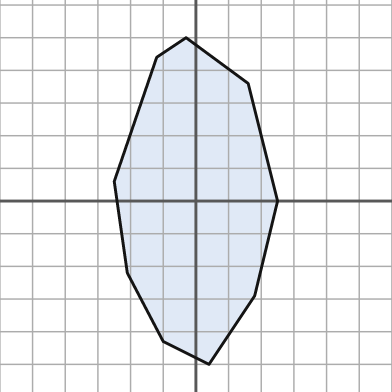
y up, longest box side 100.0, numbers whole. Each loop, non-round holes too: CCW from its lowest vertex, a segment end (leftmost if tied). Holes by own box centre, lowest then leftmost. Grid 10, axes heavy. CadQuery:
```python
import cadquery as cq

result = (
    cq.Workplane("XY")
    .moveTo(4.0, -50.0)
    .lineTo(18.0, -29.0)
    .lineTo(25.0, 0.0)
    .lineTo(16.0, 36.0)
    .lineTo(-3.0, 50.0)
    .lineTo(-12.0, 44.0)
    .lineTo(-25.0, 6.0)
    .lineTo(-21.0, -22.0)
    .lineTo(-10.0, -43.0)
    .close()
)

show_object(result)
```